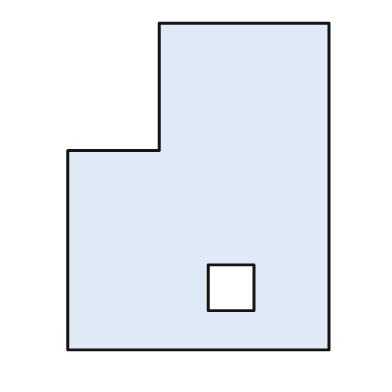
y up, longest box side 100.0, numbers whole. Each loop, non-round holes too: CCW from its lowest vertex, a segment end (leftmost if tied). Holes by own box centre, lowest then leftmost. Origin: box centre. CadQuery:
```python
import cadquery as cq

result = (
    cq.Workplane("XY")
    .moveTo(-40.0, -50.0)
    .lineTo(40.0, -50.0)
    .lineTo(40.0, 50.0)
    .lineTo(-12.0, 50.0)
    .lineTo(-12.0, 11.0)
    .lineTo(-40.0, 11.0)
    .close()
    .moveTo(3.0, -38.0)
    .lineTo(17.0, -38.0)
    .lineTo(17.0, -24.0)
    .lineTo(3.0, -24.0)
    .close()
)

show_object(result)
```